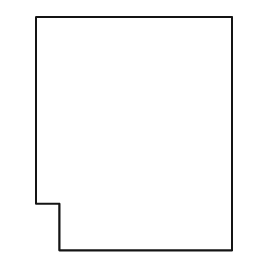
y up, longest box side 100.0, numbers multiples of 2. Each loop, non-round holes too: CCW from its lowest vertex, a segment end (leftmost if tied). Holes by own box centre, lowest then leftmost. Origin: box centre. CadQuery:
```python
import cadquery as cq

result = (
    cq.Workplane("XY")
    .moveTo(-32.0, -50.0)
    .lineTo(42.0, -50.0)
    .lineTo(42.0, 50.0)
    .lineTo(-42.0, 50.0)
    .lineTo(-42.0, -30.0)
    .lineTo(-32.0, -30.0)
    .close()
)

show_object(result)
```